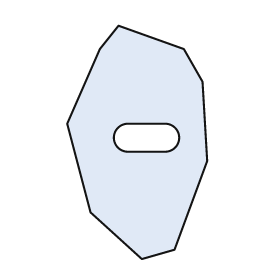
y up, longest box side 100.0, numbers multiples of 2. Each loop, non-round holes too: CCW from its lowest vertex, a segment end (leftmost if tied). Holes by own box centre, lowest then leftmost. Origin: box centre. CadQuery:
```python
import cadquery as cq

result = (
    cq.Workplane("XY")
    .moveTo(2.0, -50.0)
    .lineTo(16.0, -46.0)
    .lineTo(30.0, -8.0)
    .lineTo(28.0, 26.0)
    .lineTo(20.0, 40.0)
    .lineTo(-8.0, 50.0)
    .lineTo(-16.0, 40.0)
    .lineTo(-30.0, 8.0)
    .lineTo(-20.0, -30.0)
    .close()
    .moveTo(-4.0, -4.0)
    .lineTo(12.0, -4.0)
    .threePointArc((18.0, 2.0), (12.0, 8.0))
    .lineTo(-4.0, 8.0)
    .threePointArc((-10.0, 2.0), (-4.0, -4.0))
    .close()
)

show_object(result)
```